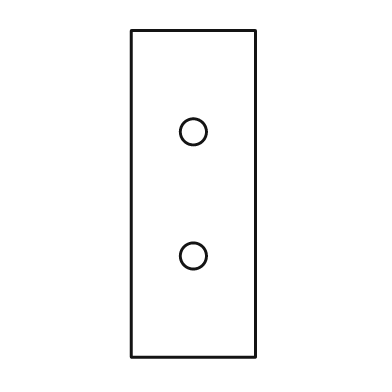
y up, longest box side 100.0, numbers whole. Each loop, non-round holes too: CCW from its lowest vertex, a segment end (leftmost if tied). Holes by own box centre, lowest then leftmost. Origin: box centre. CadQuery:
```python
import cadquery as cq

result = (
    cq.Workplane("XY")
    .moveTo(-19.0, -50.0)
    .lineTo(19.0, -50.0)
    .lineTo(19.0, 50.0)
    .lineTo(-19.0, 50.0)
    .close()
    .moveTo(0.0, -19.0)
    .circle(4.0)
    .moveTo(0.0, 19.0)
    .circle(4.0)
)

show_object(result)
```